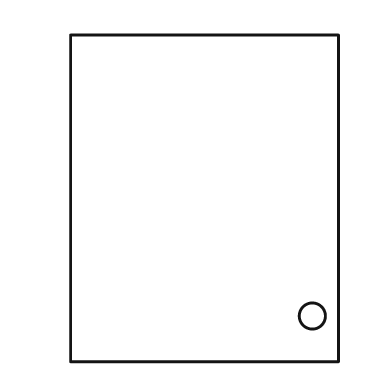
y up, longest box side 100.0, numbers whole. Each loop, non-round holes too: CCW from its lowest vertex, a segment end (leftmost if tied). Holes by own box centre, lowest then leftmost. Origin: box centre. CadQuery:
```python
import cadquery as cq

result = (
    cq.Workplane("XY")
    .moveTo(-41.0, -50.0)
    .lineTo(41.0, -50.0)
    .lineTo(41.0, 50.0)
    .lineTo(-41.0, 50.0)
    .close()
    .moveTo(33.0, -36.0)
    .circle(4.0)
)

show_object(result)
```